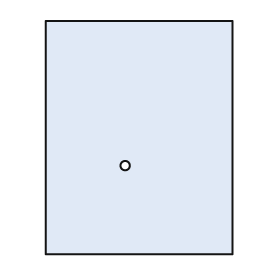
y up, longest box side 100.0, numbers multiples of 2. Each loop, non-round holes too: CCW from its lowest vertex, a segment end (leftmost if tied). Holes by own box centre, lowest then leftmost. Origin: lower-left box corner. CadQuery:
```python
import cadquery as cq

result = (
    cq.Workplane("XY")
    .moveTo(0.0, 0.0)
    .lineTo(80.0, 0.0)
    .lineTo(80.0, 100.0)
    .lineTo(0.0, 100.0)
    .close()
    .moveTo(34.0, 38.0)
    .circle(2.0)
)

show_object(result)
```